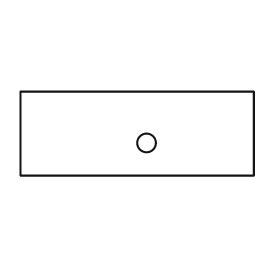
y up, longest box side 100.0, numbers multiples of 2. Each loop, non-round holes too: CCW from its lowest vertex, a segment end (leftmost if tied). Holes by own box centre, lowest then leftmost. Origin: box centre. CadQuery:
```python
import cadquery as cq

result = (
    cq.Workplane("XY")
    .moveTo(-50.0, -18.0)
    .lineTo(50.0, -18.0)
    .lineTo(50.0, 18.0)
    .lineTo(-50.0, 18.0)
    .close()
    .moveTo(4.0, -4.0)
    .circle(4.0)
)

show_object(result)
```